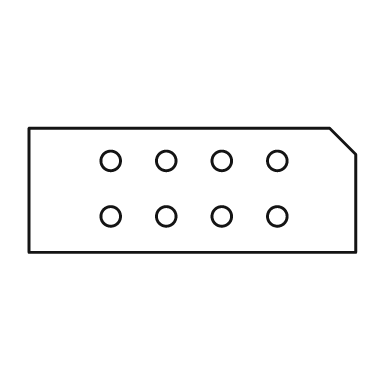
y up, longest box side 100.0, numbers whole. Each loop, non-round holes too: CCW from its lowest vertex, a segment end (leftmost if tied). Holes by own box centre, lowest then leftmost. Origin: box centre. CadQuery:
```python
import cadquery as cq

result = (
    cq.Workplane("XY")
    .moveTo(-50.0, -19.0)
    .lineTo(50.0, -19.0)
    .lineTo(50.0, 11.0)
    .lineTo(42.0, 19.0)
    .lineTo(-50.0, 19.0)
    .close()
    .moveTo(-25.0, -8.0)
    .circle(3.0)
    .moveTo(-8.0, -8.0)
    .circle(3.0)
    .moveTo(9.0, -8.0)
    .circle(3.0)
    .moveTo(26.0, -8.0)
    .circle(3.0)
    .moveTo(-25.0, 9.0)
    .circle(3.0)
    .moveTo(-8.0, 9.0)
    .circle(3.0)
    .moveTo(9.0, 9.0)
    .circle(3.0)
    .moveTo(26.0, 9.0)
    .circle(3.0)
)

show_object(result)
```